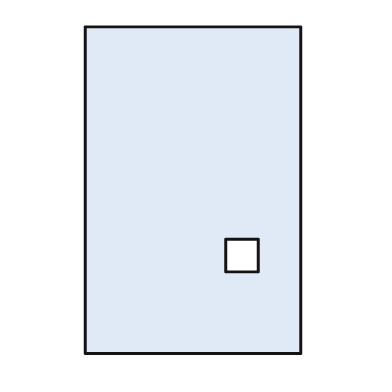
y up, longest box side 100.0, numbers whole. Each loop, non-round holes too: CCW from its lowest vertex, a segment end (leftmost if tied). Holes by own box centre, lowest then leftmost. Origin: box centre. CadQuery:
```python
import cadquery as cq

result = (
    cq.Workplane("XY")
    .moveTo(-33.0, -50.0)
    .lineTo(33.0, -50.0)
    .lineTo(33.0, 50.0)
    .lineTo(-33.0, 50.0)
    .close()
    .moveTo(10.0, -25.0)
    .lineTo(20.0, -25.0)
    .lineTo(20.0, -15.0)
    .lineTo(10.0, -15.0)
    .close()
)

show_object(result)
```